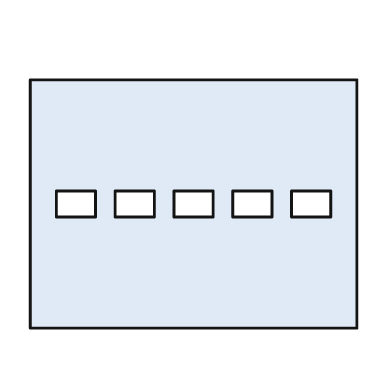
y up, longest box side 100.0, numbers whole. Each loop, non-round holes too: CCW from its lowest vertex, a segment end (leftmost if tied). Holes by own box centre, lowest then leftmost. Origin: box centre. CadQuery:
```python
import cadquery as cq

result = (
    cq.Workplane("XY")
    .moveTo(-50.0, -38.0)
    .lineTo(50.0, -38.0)
    .lineTo(50.0, 38.0)
    .lineTo(-50.0, 38.0)
    .close()
    .moveTo(-42.0, -4.0)
    .lineTo(-30.0, -4.0)
    .lineTo(-30.0, 4.0)
    .lineTo(-42.0, 4.0)
    .close()
    .moveTo(-24.0, -4.0)
    .lineTo(-12.0, -4.0)
    .lineTo(-12.0, 4.0)
    .lineTo(-24.0, 4.0)
    .close()
    .moveTo(-6.0, -4.0)
    .lineTo(6.0, -4.0)
    .lineTo(6.0, 4.0)
    .lineTo(-6.0, 4.0)
    .close()
    .moveTo(12.0, -4.0)
    .lineTo(24.0, -4.0)
    .lineTo(24.0, 4.0)
    .lineTo(12.0, 4.0)
    .close()
    .moveTo(30.0, -4.0)
    .lineTo(42.0, -4.0)
    .lineTo(42.0, 4.0)
    .lineTo(30.0, 4.0)
    .close()
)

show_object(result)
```